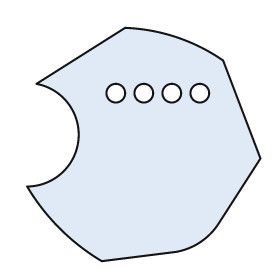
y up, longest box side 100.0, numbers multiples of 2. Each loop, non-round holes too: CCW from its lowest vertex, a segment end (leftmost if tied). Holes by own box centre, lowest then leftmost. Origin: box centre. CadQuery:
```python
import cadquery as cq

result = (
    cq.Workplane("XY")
    .moveTo(-18.0, -50.0)
    .lineTo(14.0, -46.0)
    .threePointArc((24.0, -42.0), (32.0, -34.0))
    .lineTo(50.0, -6.0)
    .lineTo(34.0, 36.0)
    .threePointArc((14.0, 46.0), (-8.0, 50.0))
    .lineTo(-46.0, 26.0)
    .threePointArc((-28.0, 2.0), (-50.0, -18.0))
    .threePointArc((-36.0, -36.0), (-18.0, -50.0))
    .close()
    .moveTo(-12.0, 22.0)
    .circle(4.0)
    .moveTo(0.0, 22.0)
    .circle(4.0)
    .moveTo(12.0, 22.0)
    .circle(4.0)
    .moveTo(24.0, 22.0)
    .circle(4.0)
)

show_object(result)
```